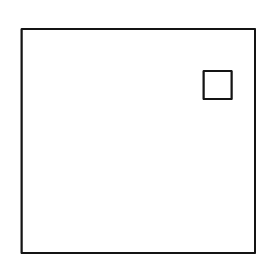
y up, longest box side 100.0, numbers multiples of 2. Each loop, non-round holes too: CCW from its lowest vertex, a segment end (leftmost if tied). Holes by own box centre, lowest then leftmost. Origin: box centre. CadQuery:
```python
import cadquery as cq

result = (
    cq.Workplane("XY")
    .moveTo(-50.0, -48.0)
    .lineTo(50.0, -48.0)
    .lineTo(50.0, 48.0)
    .lineTo(-50.0, 48.0)
    .close()
    .moveTo(28.0, 18.0)
    .lineTo(40.0, 18.0)
    .lineTo(40.0, 30.0)
    .lineTo(28.0, 30.0)
    .close()
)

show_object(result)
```